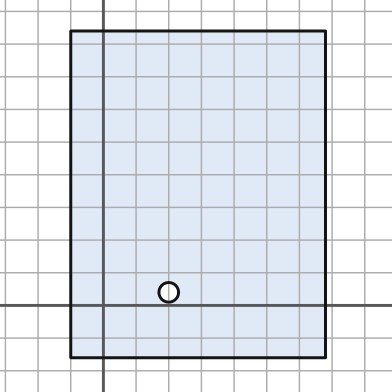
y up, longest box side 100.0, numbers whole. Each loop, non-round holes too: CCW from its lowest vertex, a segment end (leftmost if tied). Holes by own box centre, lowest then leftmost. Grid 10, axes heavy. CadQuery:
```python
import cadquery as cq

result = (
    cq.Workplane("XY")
    .moveTo(-10.0, -16.0)
    .lineTo(68.0, -16.0)
    .lineTo(68.0, 84.0)
    .lineTo(-10.0, 84.0)
    .close()
    .moveTo(20.0, 4.0)
    .circle(3.0)
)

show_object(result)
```